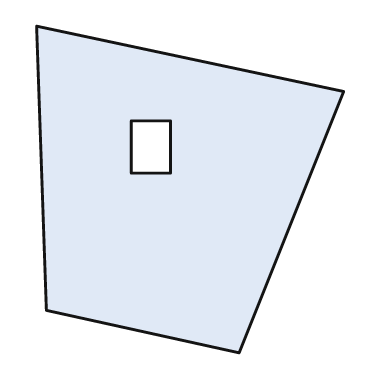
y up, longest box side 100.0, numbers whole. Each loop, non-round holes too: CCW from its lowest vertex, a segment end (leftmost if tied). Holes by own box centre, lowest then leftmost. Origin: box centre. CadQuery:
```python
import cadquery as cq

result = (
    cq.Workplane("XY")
    .moveTo(15.0, -50.0)
    .lineTo(47.0, 30.0)
    .lineTo(-47.0, 50.0)
    .lineTo(-44.0, -37.0)
    .close()
    .moveTo(-18.0, 5.0)
    .lineTo(-6.0, 5.0)
    .lineTo(-6.0, 21.0)
    .lineTo(-18.0, 21.0)
    .close()
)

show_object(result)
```